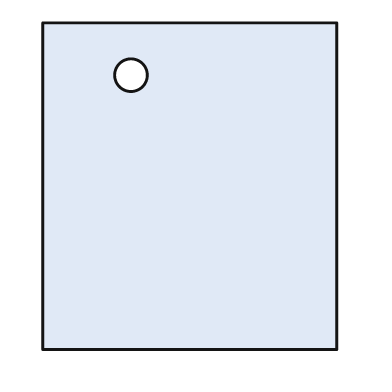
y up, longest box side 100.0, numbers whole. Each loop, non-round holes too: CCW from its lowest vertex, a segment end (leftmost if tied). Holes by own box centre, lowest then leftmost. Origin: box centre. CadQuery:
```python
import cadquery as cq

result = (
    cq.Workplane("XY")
    .moveTo(-45.0, -50.0)
    .lineTo(45.0, -50.0)
    .lineTo(45.0, 50.0)
    .lineTo(-45.0, 50.0)
    .close()
    .moveTo(-18.0, 34.0)
    .circle(5.0)
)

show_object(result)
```